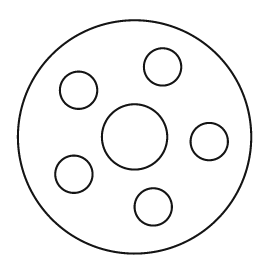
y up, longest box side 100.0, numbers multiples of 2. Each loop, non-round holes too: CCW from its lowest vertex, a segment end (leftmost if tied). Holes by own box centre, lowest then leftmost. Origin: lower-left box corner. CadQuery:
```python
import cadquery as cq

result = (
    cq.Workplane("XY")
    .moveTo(50.0, 50.0)
    .circle(50.0)
    .moveTo(58.0, 20.0)
    .circle(8.0)
    .moveTo(24.0, 34.0)
    .circle(8.0)
    .moveTo(82.0, 48.0)
    .circle(8.0)
    .moveTo(50.0, 50.0)
    .circle(14.0)
    .moveTo(26.0, 70.0)
    .circle(8.0)
    .moveTo(62.0, 80.0)
    .circle(8.0)
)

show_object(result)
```